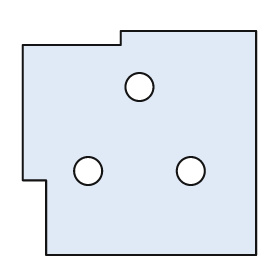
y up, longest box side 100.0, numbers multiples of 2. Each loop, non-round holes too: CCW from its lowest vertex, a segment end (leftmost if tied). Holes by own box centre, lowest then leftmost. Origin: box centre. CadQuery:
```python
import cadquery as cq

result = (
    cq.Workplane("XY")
    .moveTo(-40.0, -48.0)
    .lineTo(50.0, -48.0)
    .lineTo(50.0, 48.0)
    .lineTo(-8.0, 48.0)
    .lineTo(-8.0, 42.0)
    .lineTo(-50.0, 42.0)
    .lineTo(-50.0, -16.0)
    .lineTo(-40.0, -16.0)
    .close()
    .moveTo(-22.0, -12.0)
    .circle(6.0)
    .moveTo(22.0, -12.0)
    .circle(6.0)
    .moveTo(0.0, 24.0)
    .circle(6.0)
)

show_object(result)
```